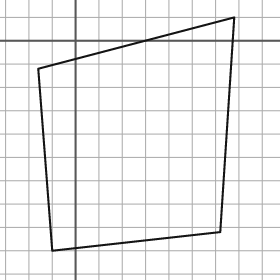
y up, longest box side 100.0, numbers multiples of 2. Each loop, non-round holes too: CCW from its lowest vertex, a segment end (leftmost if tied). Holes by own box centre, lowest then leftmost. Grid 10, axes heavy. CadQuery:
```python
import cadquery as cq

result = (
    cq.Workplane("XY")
    .moveTo(-10.0, -90.0)
    .lineTo(62.0, -82.0)
    .lineTo(68.0, 10.0)
    .lineTo(-16.0, -12.0)
    .close()
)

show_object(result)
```